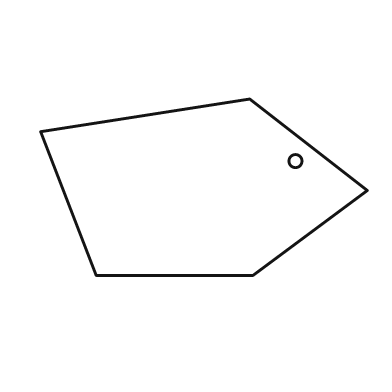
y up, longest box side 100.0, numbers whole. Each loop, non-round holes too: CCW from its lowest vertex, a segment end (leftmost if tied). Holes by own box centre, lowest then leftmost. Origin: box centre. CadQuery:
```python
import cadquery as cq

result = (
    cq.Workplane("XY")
    .moveTo(-33.0, -27.0)
    .lineTo(15.0, -27.0)
    .lineTo(50.0, -1.0)
    .lineTo(14.0, 27.0)
    .lineTo(-50.0, 17.0)
    .close()
    .moveTo(28.0, 8.0)
    .circle(2.0)
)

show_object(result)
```